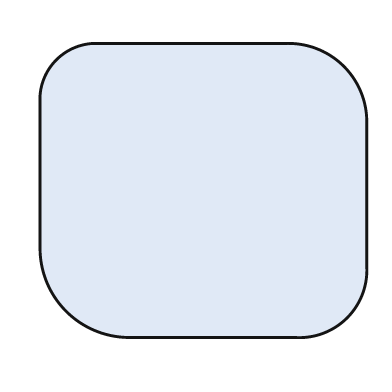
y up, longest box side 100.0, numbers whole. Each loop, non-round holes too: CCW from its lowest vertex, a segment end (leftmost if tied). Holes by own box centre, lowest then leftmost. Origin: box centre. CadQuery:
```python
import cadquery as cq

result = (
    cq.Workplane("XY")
    .moveTo(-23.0, -45.0)
    .lineTo(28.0, -45.0)
    .threePointArc((44.0, -39.0), (50.0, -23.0))
    .lineTo(50.0, 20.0)
    .threePointArc((43.0, 38.0), (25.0, 45.0))
    .lineTo(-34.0, 45.0)
    .threePointArc((-45.0, 40.0), (-50.0, 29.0))
    .lineTo(-50.0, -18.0)
    .threePointArc((-42.0, -37.0), (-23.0, -45.0))
    .close()
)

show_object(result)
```